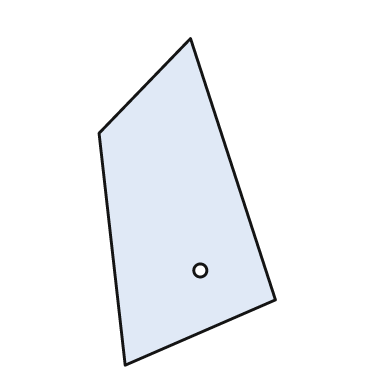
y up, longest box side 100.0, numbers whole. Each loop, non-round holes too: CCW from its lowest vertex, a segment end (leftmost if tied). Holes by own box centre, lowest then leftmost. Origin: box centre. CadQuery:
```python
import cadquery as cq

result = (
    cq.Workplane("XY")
    .moveTo(-19.0, -50.0)
    .lineTo(27.0, -30.0)
    .lineTo(1.0, 50.0)
    .lineTo(-27.0, 21.0)
    .close()
    .moveTo(4.0, -21.0)
    .circle(2.0)
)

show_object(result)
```